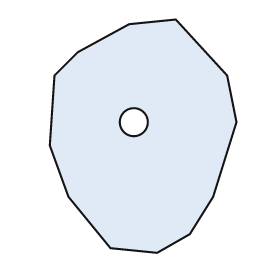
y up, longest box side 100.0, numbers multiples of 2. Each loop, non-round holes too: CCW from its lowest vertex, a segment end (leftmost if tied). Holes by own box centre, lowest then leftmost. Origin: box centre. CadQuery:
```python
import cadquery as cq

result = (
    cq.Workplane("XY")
    .moveTo(6.0, -50.0)
    .lineTo(20.0, -42.0)
    .lineTo(30.0, -26.0)
    .lineTo(40.0, 6.0)
    .lineTo(36.0, 26.0)
    .lineTo(14.0, 50.0)
    .lineTo(-6.0, 48.0)
    .lineTo(-28.0, 36.0)
    .lineTo(-38.0, 26.0)
    .lineTo(-40.0, -4.0)
    .lineTo(-32.0, -26.0)
    .lineTo(-14.0, -48.0)
    .close()
    .moveTo(-4.0, 6.0)
    .circle(6.0)
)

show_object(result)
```